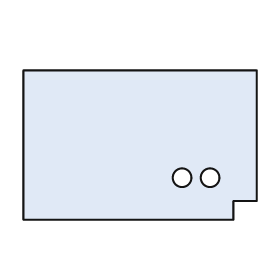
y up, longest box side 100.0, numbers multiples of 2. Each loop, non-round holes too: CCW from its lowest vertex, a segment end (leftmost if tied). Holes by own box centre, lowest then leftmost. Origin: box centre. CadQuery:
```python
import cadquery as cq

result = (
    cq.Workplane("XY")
    .moveTo(-50.0, -32.0)
    .lineTo(40.0, -32.0)
    .lineTo(40.0, -24.0)
    .lineTo(50.0, -24.0)
    .lineTo(50.0, 32.0)
    .lineTo(-50.0, 32.0)
    .close()
    .moveTo(18.0, -14.0)
    .circle(4.0)
    .moveTo(30.0, -14.0)
    .circle(4.0)
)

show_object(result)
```